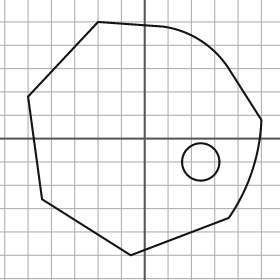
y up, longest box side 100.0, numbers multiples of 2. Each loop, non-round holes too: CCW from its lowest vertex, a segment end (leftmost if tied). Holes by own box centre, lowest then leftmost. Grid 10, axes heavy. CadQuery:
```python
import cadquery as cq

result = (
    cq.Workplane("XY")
    .moveTo(-6.0, -50.0)
    .lineTo(36.0, -34.0)
    .threePointArc((46.0, -14.0), (50.0, 8.0))
    .lineTo(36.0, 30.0)
    .threePointArc((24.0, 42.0), (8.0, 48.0))
    .lineTo(-20.0, 50.0)
    .lineTo(-50.0, 18.0)
    .lineTo(-44.0, -26.0)
    .close()
    .moveTo(24.0, -10.0)
    .circle(8.0)
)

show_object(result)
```